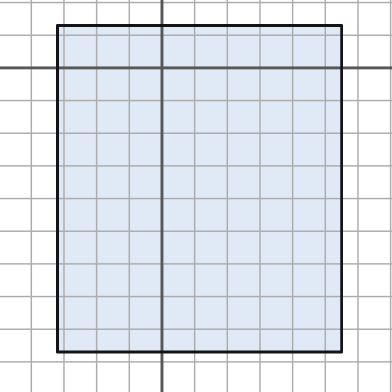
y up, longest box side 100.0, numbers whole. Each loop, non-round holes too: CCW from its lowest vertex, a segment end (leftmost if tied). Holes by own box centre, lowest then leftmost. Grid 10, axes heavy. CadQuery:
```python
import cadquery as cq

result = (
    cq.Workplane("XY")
    .moveTo(-32.0, -87.0)
    .lineTo(55.0, -87.0)
    .lineTo(55.0, 13.0)
    .lineTo(-32.0, 13.0)
    .close()
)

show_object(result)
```